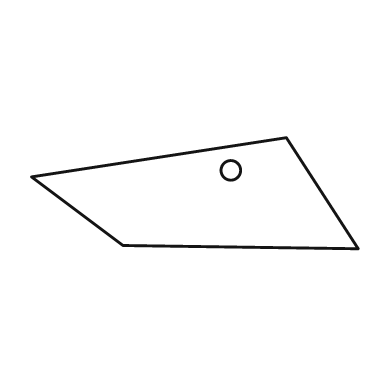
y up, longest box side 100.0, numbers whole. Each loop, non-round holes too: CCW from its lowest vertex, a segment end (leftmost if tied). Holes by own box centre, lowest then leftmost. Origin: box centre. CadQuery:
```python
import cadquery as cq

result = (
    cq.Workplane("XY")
    .moveTo(50.0, -17.0)
    .lineTo(28.0, 17.0)
    .lineTo(-50.0, 5.0)
    .lineTo(-22.0, -16.0)
    .close()
    .moveTo(11.0, 7.0)
    .circle(3.0)
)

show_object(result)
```